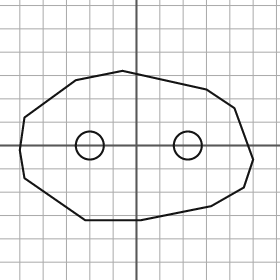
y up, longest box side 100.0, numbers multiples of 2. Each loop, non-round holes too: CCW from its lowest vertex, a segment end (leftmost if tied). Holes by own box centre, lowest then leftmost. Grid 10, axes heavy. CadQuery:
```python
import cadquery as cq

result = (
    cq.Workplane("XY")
    .moveTo(-22.0, -32.0)
    .lineTo(2.0, -32.0)
    .lineTo(32.0, -26.0)
    .lineTo(46.0, -18.0)
    .lineTo(50.0, -6.0)
    .lineTo(42.0, 16.0)
    .lineTo(30.0, 24.0)
    .lineTo(-6.0, 32.0)
    .lineTo(-26.0, 28.0)
    .lineTo(-48.0, 12.0)
    .lineTo(-50.0, -2.0)
    .lineTo(-48.0, -14.0)
    .close()
    .moveTo(-20.0, 0.0)
    .circle(6.0)
    .moveTo(22.0, 0.0)
    .circle(6.0)
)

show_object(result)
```